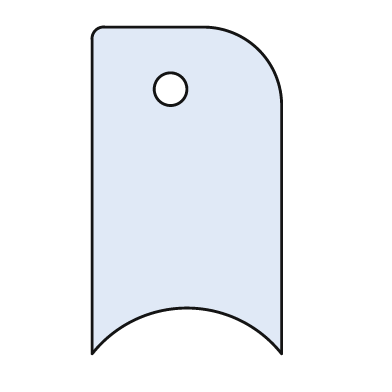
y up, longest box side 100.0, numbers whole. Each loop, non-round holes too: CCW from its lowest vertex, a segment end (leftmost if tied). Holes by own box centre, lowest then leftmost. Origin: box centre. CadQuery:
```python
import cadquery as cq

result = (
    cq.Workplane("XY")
    .moveTo(-29.0, -50.0)
    .threePointArc((0.0, -36.0), (29.0, -50.0))
    .lineTo(29.0, 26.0)
    .threePointArc((22.0, 43.0), (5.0, 50.0))
    .lineTo(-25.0, 50.0)
    .threePointArc((-28.0, 49.0), (-29.0, 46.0))
    .close()
    .moveTo(-5.0, 31.0)
    .circle(5.0)
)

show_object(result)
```